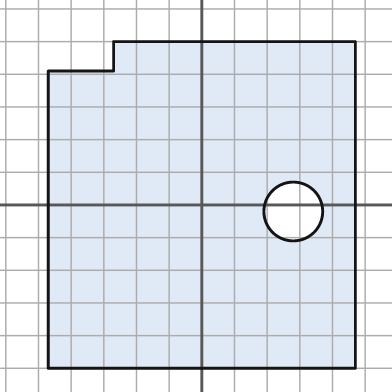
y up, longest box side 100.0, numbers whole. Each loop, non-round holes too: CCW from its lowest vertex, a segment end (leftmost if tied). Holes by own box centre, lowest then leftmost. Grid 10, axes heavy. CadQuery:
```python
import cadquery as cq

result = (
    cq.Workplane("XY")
    .moveTo(-47.0, -50.0)
    .lineTo(47.0, -50.0)
    .lineTo(47.0, 50.0)
    .lineTo(-27.0, 50.0)
    .lineTo(-27.0, 41.0)
    .lineTo(-47.0, 41.0)
    .close()
    .moveTo(28.0, -2.0)
    .circle(9.0)
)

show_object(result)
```